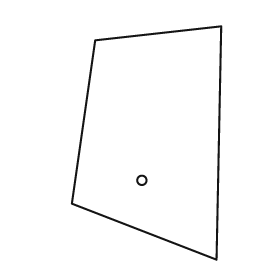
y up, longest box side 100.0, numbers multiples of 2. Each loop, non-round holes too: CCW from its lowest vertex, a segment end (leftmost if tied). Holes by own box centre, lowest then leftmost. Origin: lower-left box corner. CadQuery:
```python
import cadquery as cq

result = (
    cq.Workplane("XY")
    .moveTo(62.0, 0.0)
    .lineTo(64.0, 100.0)
    .lineTo(10.0, 94.0)
    .lineTo(0.0, 24.0)
    .close()
    .moveTo(30.0, 34.0)
    .circle(2.0)
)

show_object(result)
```